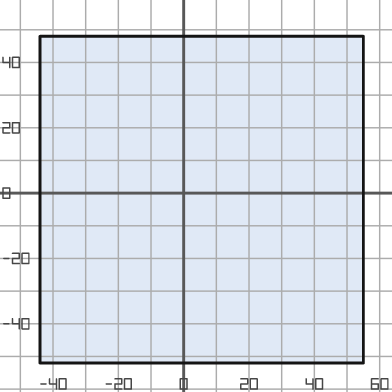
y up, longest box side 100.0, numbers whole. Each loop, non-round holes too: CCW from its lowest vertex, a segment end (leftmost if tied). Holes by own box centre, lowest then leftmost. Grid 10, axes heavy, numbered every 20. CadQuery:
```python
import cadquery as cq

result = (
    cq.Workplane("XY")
    .moveTo(-44.0, -52.0)
    .lineTo(55.0, -52.0)
    .lineTo(55.0, 48.0)
    .lineTo(-44.0, 48.0)
    .close()
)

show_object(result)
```